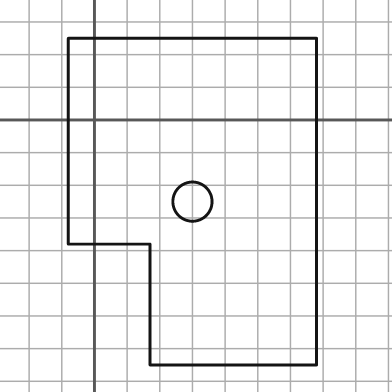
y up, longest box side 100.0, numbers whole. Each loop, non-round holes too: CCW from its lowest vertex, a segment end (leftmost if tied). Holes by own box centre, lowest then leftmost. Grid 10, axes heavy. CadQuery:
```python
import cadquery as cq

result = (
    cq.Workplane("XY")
    .moveTo(17.0, -75.0)
    .lineTo(68.0, -75.0)
    .lineTo(68.0, 25.0)
    .lineTo(-8.0, 25.0)
    .lineTo(-8.0, -38.0)
    .lineTo(17.0, -38.0)
    .close()
    .moveTo(30.0, -25.0)
    .circle(6.0)
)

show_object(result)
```